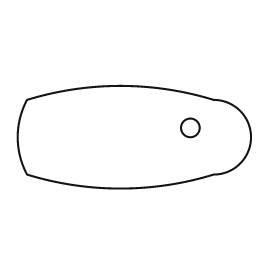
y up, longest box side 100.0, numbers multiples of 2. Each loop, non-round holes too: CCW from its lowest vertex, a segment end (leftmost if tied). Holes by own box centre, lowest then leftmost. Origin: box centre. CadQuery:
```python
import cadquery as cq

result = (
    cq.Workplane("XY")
    .moveTo(-46.0, -16.0)
    .threePointArc((-6.0, -22.0), (34.0, -16.0))
    .threePointArc((50.0, 0.0), (34.0, 16.0))
    .threePointArc((-6.0, 22.0), (-46.0, 16.0))
    .threePointArc((-50.0, 0.0), (-46.0, -16.0))
    .close()
    .moveTo(24.0, 4.0)
    .circle(4.0)
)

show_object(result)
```